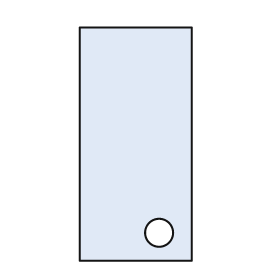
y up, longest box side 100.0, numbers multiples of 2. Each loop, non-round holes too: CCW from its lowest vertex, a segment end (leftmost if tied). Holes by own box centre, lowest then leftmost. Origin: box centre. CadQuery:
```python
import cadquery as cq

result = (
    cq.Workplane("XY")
    .moveTo(-24.0, -50.0)
    .lineTo(24.0, -50.0)
    .lineTo(24.0, 50.0)
    .lineTo(-24.0, 50.0)
    .close()
    .moveTo(10.0, -38.0)
    .circle(6.0)
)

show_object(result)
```